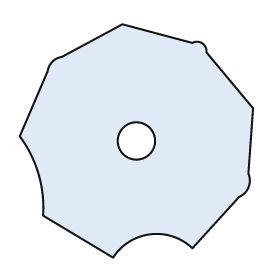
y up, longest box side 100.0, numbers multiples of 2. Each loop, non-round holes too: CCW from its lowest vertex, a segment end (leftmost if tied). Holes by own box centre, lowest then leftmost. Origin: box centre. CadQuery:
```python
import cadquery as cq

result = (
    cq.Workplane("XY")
    .moveTo(-10.0, -50.0)
    .threePointArc((6.0, -40.0), (24.0, -46.0))
    .lineTo(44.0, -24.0)
    .threePointArc((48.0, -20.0), (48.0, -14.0))
    .lineTo(50.0, 14.0)
    .lineTo(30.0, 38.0)
    .threePointArc((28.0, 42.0), (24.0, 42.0))
    .lineTo(-6.0, 50.0)
    .lineTo(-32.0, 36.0)
    .threePointArc((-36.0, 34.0), (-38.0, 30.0))
    .lineTo(-50.0, 2.0)
    .threePointArc((-42.0, -14.0), (-40.0, -32.0))
    .close()
    .moveTo(0.0, 0.0)
    .circle(8.0)
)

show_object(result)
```